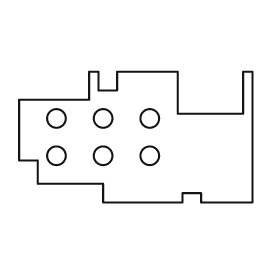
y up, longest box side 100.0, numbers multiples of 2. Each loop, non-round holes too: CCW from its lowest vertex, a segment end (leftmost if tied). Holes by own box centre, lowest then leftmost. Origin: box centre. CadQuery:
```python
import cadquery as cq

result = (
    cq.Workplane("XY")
    .moveTo(-14.0, -28.0)
    .lineTo(20.0, -28.0)
    .lineTo(20.0, -24.0)
    .lineTo(28.0, -24.0)
    .lineTo(28.0, -28.0)
    .lineTo(50.0, -28.0)
    .lineTo(50.0, 28.0)
    .lineTo(46.0, 28.0)
    .lineTo(46.0, 10.0)
    .lineTo(18.0, 10.0)
    .lineTo(18.0, 28.0)
    .lineTo(-8.0, 28.0)
    .lineTo(-8.0, 20.0)
    .lineTo(-16.0, 20.0)
    .lineTo(-16.0, 28.0)
    .lineTo(-20.0, 28.0)
    .lineTo(-20.0, 16.0)
    .lineTo(-50.0, 16.0)
    .lineTo(-50.0, -10.0)
    .lineTo(-42.0, -10.0)
    .lineTo(-42.0, -20.0)
    .lineTo(-14.0, -20.0)
    .close()
    .moveTo(-34.0, -8.0)
    .circle(4.0)
    .moveTo(-14.0, -8.0)
    .circle(4.0)
    .moveTo(6.0, -8.0)
    .circle(4.0)
    .moveTo(-34.0, 8.0)
    .circle(4.0)
    .moveTo(-14.0, 8.0)
    .circle(4.0)
    .moveTo(6.0, 8.0)
    .circle(4.0)
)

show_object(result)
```